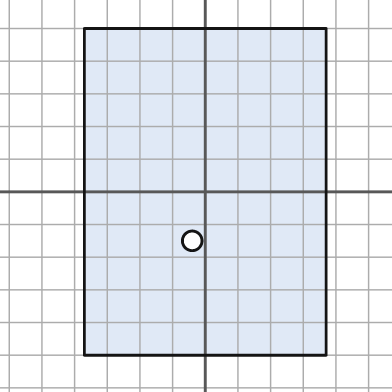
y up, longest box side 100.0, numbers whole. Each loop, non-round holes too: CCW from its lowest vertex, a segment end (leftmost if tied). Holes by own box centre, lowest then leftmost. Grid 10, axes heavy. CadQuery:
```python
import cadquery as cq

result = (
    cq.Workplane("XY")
    .moveTo(-37.0, -50.0)
    .lineTo(37.0, -50.0)
    .lineTo(37.0, 50.0)
    .lineTo(-37.0, 50.0)
    .close()
    .moveTo(-4.0, -15.0)
    .circle(3.0)
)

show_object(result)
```